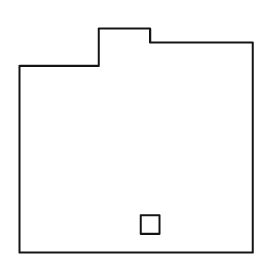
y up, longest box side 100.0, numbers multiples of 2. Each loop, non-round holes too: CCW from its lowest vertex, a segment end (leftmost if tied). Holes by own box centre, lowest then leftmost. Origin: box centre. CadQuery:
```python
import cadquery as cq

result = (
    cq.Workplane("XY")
    .moveTo(-50.0, -48.0)
    .lineTo(50.0, -48.0)
    .lineTo(50.0, 42.0)
    .lineTo(6.0, 42.0)
    .lineTo(6.0, 48.0)
    .lineTo(-16.0, 48.0)
    .lineTo(-16.0, 32.0)
    .lineTo(-50.0, 32.0)
    .close()
    .moveTo(2.0, -40.0)
    .lineTo(10.0, -40.0)
    .lineTo(10.0, -32.0)
    .lineTo(2.0, -32.0)
    .close()
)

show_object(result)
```